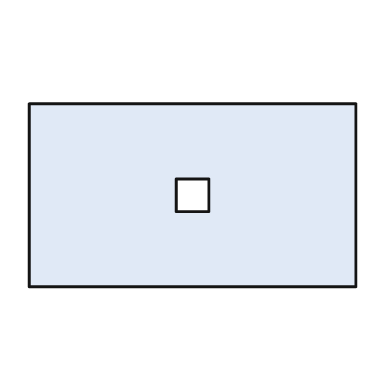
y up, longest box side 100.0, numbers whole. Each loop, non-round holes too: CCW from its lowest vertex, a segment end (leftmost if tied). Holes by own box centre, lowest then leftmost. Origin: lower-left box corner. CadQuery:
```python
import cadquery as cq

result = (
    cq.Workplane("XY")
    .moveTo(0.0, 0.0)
    .lineTo(100.0, 0.0)
    .lineTo(100.0, 56.0)
    .lineTo(0.0, 56.0)
    .close()
    .moveTo(45.0, 23.0)
    .lineTo(55.0, 23.0)
    .lineTo(55.0, 33.0)
    .lineTo(45.0, 33.0)
    .close()
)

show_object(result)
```